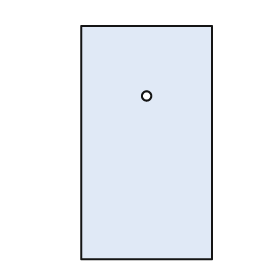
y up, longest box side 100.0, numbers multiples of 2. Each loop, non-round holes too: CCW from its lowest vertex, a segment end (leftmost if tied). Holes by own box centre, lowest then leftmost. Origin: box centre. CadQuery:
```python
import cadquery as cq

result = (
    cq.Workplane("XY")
    .moveTo(-28.0, -50.0)
    .lineTo(28.0, -50.0)
    .lineTo(28.0, 50.0)
    .lineTo(-28.0, 50.0)
    .close()
    .moveTo(0.0, 20.0)
    .circle(2.0)
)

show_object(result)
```